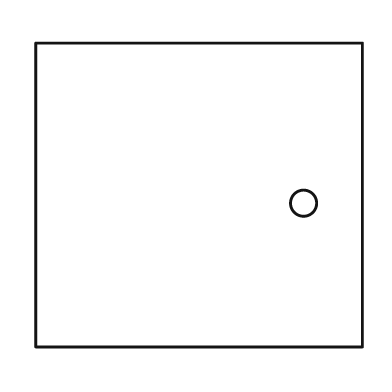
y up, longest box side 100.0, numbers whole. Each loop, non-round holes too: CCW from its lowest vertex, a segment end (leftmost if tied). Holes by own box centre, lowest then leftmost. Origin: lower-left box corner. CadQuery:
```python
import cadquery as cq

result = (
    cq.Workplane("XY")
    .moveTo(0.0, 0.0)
    .lineTo(100.0, 0.0)
    .lineTo(100.0, 93.0)
    .lineTo(0.0, 93.0)
    .close()
    .moveTo(82.0, 44.0)
    .circle(4.0)
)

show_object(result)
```